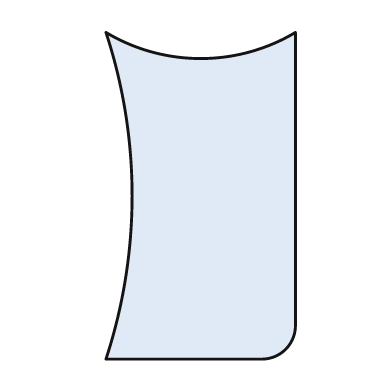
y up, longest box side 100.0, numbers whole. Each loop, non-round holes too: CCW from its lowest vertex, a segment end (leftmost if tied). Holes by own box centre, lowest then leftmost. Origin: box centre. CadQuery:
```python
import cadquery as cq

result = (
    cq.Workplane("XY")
    .moveTo(-29.0, -50.0)
    .lineTo(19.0, -50.0)
    .threePointArc((26.0, -47.0), (29.0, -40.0))
    .lineTo(29.0, 50.0)
    .threePointArc((0.0, 42.0), (-29.0, 50.0))
    .threePointArc((-21.0, 0.0), (-29.0, -50.0))
    .close()
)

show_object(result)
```